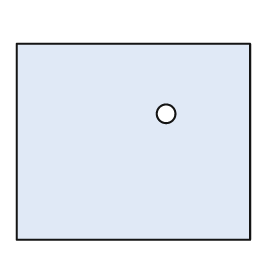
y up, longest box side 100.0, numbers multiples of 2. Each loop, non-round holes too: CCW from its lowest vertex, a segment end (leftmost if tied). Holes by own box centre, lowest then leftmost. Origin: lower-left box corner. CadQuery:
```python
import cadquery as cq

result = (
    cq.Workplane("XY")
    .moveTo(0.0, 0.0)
    .lineTo(100.0, 0.0)
    .lineTo(100.0, 84.0)
    .lineTo(0.0, 84.0)
    .close()
    .moveTo(64.0, 54.0)
    .circle(4.0)
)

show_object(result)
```